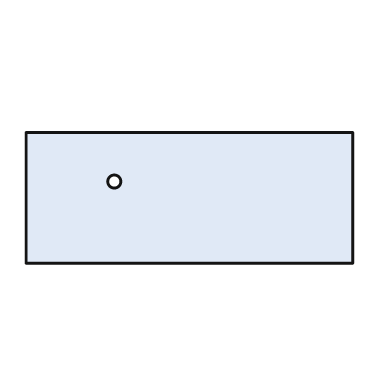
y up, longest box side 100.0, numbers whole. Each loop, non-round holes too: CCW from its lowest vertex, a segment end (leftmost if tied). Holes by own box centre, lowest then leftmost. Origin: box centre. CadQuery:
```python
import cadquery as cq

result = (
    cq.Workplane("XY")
    .moveTo(-50.0, -20.0)
    .lineTo(50.0, -20.0)
    .lineTo(50.0, 20.0)
    .lineTo(-50.0, 20.0)
    .close()
    .moveTo(-23.0, 5.0)
    .circle(2.0)
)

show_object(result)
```